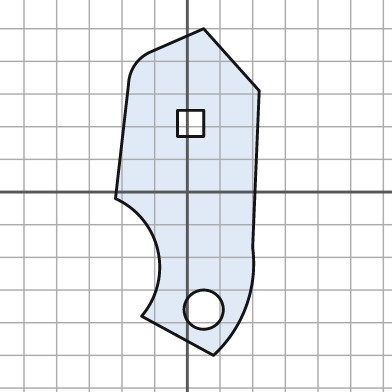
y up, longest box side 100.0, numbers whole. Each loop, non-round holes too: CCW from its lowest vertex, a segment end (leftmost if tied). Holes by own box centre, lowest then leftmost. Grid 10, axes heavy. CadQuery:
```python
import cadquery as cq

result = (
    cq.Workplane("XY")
    .moveTo(8.0, -50.0)
    .threePointArc((18.0, -35.0), (20.0, -17.0))
    .lineTo(22.0, 31.0)
    .lineTo(5.0, 50.0)
    .lineTo(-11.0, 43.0)
    .threePointArc((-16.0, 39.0), (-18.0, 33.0))
    .lineTo(-22.0, -2.0)
    .threePointArc((-9.0, -18.0), (-14.0, -38.0))
    .close()
    .moveTo(5.0, -36.0)
    .circle(6.0)
    .moveTo(-3.0, 17.0)
    .lineTo(5.0, 17.0)
    .lineTo(5.0, 25.0)
    .lineTo(-3.0, 25.0)
    .close()
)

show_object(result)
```